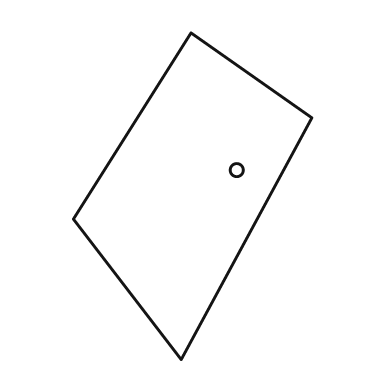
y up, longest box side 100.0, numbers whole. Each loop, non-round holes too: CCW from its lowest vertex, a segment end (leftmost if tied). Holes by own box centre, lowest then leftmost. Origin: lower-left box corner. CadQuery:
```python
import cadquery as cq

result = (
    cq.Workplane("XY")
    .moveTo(33.0, 0.0)
    .lineTo(73.0, 74.0)
    .lineTo(36.0, 100.0)
    .lineTo(0.0, 43.0)
    .close()
    .moveTo(50.0, 58.0)
    .circle(2.0)
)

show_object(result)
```